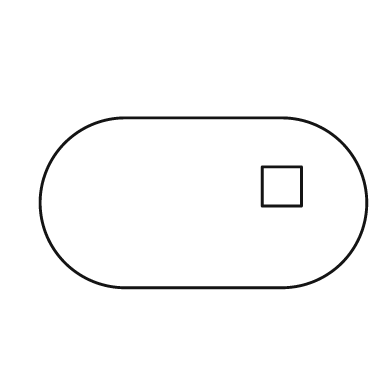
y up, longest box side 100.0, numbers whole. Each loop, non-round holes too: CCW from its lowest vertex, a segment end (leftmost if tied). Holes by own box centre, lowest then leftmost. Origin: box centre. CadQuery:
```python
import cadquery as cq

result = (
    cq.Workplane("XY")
    .moveTo(-24.0, -26.0)
    .lineTo(24.0, -26.0)
    .threePointArc((50.0, 0.0), (24.0, 26.0))
    .lineTo(-24.0, 26.0)
    .threePointArc((-50.0, 0.0), (-24.0, -26.0))
    .close()
    .moveTo(18.0, -1.0)
    .lineTo(30.0, -1.0)
    .lineTo(30.0, 11.0)
    .lineTo(18.0, 11.0)
    .close()
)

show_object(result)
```